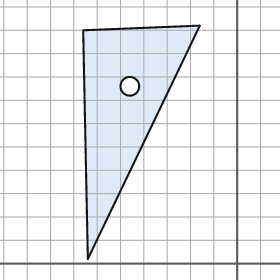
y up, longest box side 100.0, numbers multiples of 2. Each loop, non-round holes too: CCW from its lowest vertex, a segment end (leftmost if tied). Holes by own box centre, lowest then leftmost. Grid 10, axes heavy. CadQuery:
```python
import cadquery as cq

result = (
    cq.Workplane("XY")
    .moveTo(-64.0, 2.0)
    .lineTo(-16.0, 102.0)
    .lineTo(-66.0, 100.0)
    .close()
    .moveTo(-46.0, 76.0)
    .circle(4.0)
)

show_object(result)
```